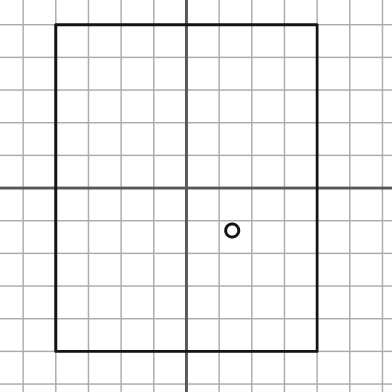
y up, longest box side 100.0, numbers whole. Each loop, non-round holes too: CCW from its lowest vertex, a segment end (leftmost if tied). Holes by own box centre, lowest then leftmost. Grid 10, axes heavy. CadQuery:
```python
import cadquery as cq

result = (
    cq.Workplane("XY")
    .moveTo(-40.0, -50.0)
    .lineTo(40.0, -50.0)
    .lineTo(40.0, 50.0)
    .lineTo(-40.0, 50.0)
    .close()
    .moveTo(14.0, -13.0)
    .circle(2.0)
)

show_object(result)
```